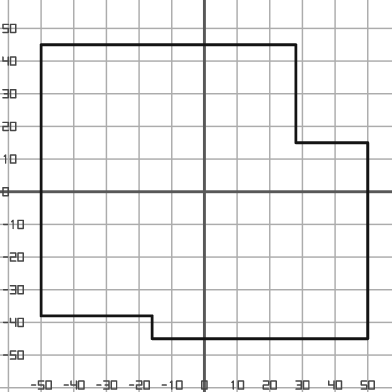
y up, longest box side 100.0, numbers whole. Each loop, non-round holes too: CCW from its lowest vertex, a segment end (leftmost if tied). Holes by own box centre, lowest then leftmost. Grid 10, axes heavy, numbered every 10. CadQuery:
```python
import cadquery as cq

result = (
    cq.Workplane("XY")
    .moveTo(-16.0, -45.0)
    .lineTo(50.0, -45.0)
    .lineTo(50.0, 15.0)
    .lineTo(28.0, 15.0)
    .lineTo(28.0, 45.0)
    .lineTo(-50.0, 45.0)
    .lineTo(-50.0, -38.0)
    .lineTo(-16.0, -38.0)
    .close()
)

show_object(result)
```